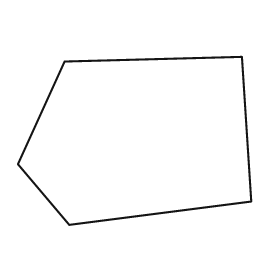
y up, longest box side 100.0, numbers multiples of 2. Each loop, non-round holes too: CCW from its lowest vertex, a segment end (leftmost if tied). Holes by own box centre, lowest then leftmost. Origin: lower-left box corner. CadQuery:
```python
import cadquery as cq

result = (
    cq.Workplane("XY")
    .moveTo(22.0, 0.0)
    .lineTo(100.0, 10.0)
    .lineTo(96.0, 72.0)
    .lineTo(20.0, 70.0)
    .lineTo(0.0, 26.0)
    .close()
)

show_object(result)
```